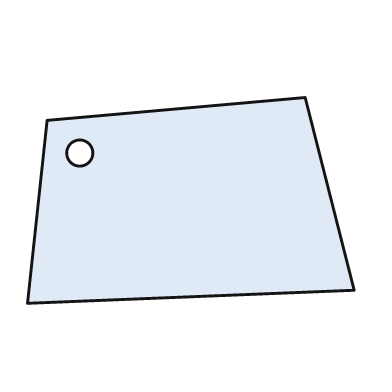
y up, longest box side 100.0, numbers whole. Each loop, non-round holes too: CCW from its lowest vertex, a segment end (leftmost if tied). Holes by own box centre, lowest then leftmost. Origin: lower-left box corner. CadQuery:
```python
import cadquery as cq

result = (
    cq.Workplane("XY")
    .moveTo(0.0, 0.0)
    .lineTo(100.0, 4.0)
    .lineTo(85.0, 63.0)
    .lineTo(6.0, 56.0)
    .close()
    .moveTo(16.0, 46.0)
    .circle(4.0)
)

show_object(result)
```